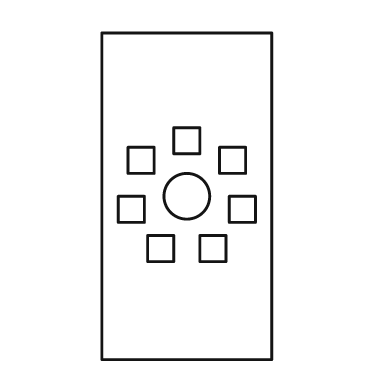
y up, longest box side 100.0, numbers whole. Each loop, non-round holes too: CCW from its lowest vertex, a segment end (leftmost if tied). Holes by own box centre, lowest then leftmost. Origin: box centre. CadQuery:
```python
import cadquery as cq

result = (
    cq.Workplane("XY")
    .moveTo(-26.0, -50.0)
    .lineTo(26.0, -50.0)
    .lineTo(26.0, 50.0)
    .lineTo(-26.0, 50.0)
    .close()
    .moveTo(-12.0, -20.0)
    .lineTo(-4.0, -20.0)
    .lineTo(-4.0, -12.0)
    .lineTo(-12.0, -12.0)
    .close()
    .moveTo(4.0, -20.0)
    .lineTo(12.0, -20.0)
    .lineTo(12.0, -12.0)
    .lineTo(4.0, -12.0)
    .close()
    .moveTo(-21.0, -8.0)
    .lineTo(-13.0, -8.0)
    .lineTo(-13.0, 0.0)
    .lineTo(-21.0, 0.0)
    .close()
    .moveTo(13.0, -8.0)
    .lineTo(21.0, -8.0)
    .lineTo(21.0, 0.0)
    .lineTo(13.0, 0.0)
    .close()
    .moveTo(0.0, 0.0)
    .circle(7.0)
    .moveTo(-18.0, 7.0)
    .lineTo(-10.0, 7.0)
    .lineTo(-10.0, 15.0)
    .lineTo(-18.0, 15.0)
    .close()
    .moveTo(10.0, 7.0)
    .lineTo(18.0, 7.0)
    .lineTo(18.0, 15.0)
    .lineTo(10.0, 15.0)
    .close()
    .moveTo(-4.0, 13.0)
    .lineTo(4.0, 13.0)
    .lineTo(4.0, 21.0)
    .lineTo(-4.0, 21.0)
    .close()
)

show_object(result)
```